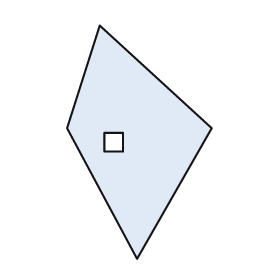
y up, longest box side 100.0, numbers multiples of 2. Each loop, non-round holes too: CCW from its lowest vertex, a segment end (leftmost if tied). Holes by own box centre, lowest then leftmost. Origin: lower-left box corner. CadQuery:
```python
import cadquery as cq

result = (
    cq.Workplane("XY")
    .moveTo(30.0, 0.0)
    .lineTo(62.0, 56.0)
    .lineTo(14.0, 100.0)
    .lineTo(0.0, 56.0)
    .close()
    .moveTo(16.0, 46.0)
    .lineTo(24.0, 46.0)
    .lineTo(24.0, 54.0)
    .lineTo(16.0, 54.0)
    .close()
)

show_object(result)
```